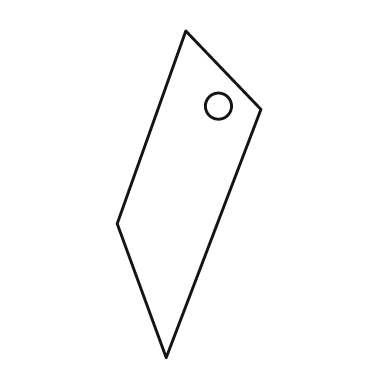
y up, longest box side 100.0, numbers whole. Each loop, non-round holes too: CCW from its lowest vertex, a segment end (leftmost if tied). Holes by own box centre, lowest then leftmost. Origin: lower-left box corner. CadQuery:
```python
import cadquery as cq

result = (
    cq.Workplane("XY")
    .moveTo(15.0, 0.0)
    .lineTo(44.0, 76.0)
    .lineTo(21.0, 100.0)
    .lineTo(0.0, 41.0)
    .close()
    .moveTo(31.0, 77.0)
    .circle(4.0)
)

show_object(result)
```